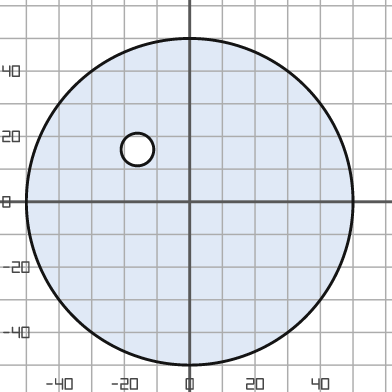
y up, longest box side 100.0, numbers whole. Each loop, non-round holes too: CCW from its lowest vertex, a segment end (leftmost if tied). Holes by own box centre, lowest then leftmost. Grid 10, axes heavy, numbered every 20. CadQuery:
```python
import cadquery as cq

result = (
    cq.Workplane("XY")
    .moveTo(0.0, 0.0)
    .circle(50.0)
    .moveTo(-16.0, 16.0)
    .circle(5.0)
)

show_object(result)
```